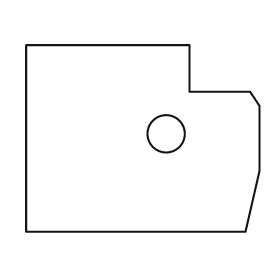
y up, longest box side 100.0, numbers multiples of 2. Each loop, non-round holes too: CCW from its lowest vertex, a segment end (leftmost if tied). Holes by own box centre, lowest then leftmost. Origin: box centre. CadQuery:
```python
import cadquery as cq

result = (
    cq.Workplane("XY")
    .moveTo(-50.0, -40.0)
    .lineTo(44.0, -40.0)
    .lineTo(50.0, -14.0)
    .lineTo(50.0, 14.0)
    .lineTo(46.0, 20.0)
    .lineTo(20.0, 20.0)
    .lineTo(20.0, 40.0)
    .lineTo(-50.0, 40.0)
    .close()
    .moveTo(10.0, 2.0)
    .circle(8.0)
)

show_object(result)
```